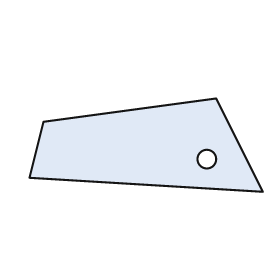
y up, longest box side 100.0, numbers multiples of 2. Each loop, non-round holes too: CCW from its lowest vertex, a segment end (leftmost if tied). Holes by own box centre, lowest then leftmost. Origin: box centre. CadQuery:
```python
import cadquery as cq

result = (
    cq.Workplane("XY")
    .moveTo(50.0, -20.0)
    .lineTo(30.0, 20.0)
    .lineTo(-44.0, 10.0)
    .lineTo(-50.0, -14.0)
    .close()
    .moveTo(26.0, -6.0)
    .circle(4.0)
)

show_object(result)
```